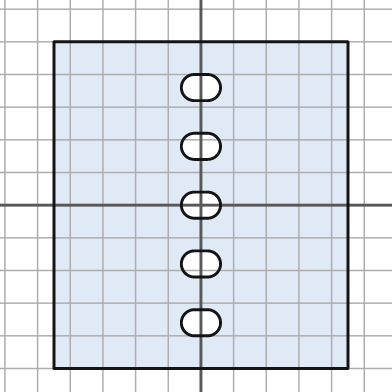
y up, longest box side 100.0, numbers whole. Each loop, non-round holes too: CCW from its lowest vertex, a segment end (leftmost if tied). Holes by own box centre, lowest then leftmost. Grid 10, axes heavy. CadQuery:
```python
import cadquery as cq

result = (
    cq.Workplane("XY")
    .moveTo(-45.0, -50.0)
    .lineTo(45.0, -50.0)
    .lineTo(45.0, 50.0)
    .lineTo(-45.0, 50.0)
    .close()
    .moveTo(-2.0, -40.0)
    .lineTo(2.0, -40.0)
    .threePointArc((6.0, -36.0), (2.0, -32.0))
    .lineTo(-2.0, -32.0)
    .threePointArc((-6.0, -36.0), (-2.0, -40.0))
    .close()
    .moveTo(-2.0, -22.0)
    .lineTo(2.0, -22.0)
    .threePointArc((6.0, -18.0), (2.0, -14.0))
    .lineTo(-2.0, -14.0)
    .threePointArc((-6.0, -18.0), (-2.0, -22.0))
    .close()
    .moveTo(-2.0, -4.0)
    .lineTo(2.0, -4.0)
    .threePointArc((6.0, 0.0), (2.0, 4.0))
    .lineTo(-2.0, 4.0)
    .threePointArc((-6.0, 0.0), (-2.0, -4.0))
    .close()
    .moveTo(-2.0, 14.0)
    .lineTo(2.0, 14.0)
    .threePointArc((6.0, 18.0), (2.0, 22.0))
    .lineTo(-2.0, 22.0)
    .threePointArc((-6.0, 18.0), (-2.0, 14.0))
    .close()
    .moveTo(-2.0, 32.0)
    .lineTo(2.0, 32.0)
    .threePointArc((6.0, 36.0), (2.0, 40.0))
    .lineTo(-2.0, 40.0)
    .threePointArc((-6.0, 36.0), (-2.0, 32.0))
    .close()
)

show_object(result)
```